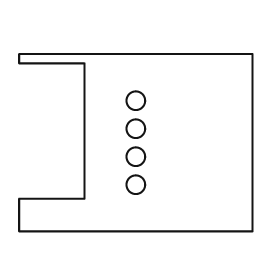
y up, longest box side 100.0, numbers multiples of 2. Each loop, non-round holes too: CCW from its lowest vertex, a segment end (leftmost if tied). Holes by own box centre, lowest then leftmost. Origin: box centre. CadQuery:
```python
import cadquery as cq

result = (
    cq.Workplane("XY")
    .moveTo(-50.0, -38.0)
    .lineTo(50.0, -38.0)
    .lineTo(50.0, 38.0)
    .lineTo(-50.0, 38.0)
    .lineTo(-50.0, 34.0)
    .lineTo(-22.0, 34.0)
    .lineTo(-22.0, -24.0)
    .lineTo(-50.0, -24.0)
    .close()
    .moveTo(0.0, -18.0)
    .circle(4.0)
    .moveTo(0.0, -6.0)
    .circle(4.0)
    .moveTo(0.0, 6.0)
    .circle(4.0)
    .moveTo(0.0, 18.0)
    .circle(4.0)
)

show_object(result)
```